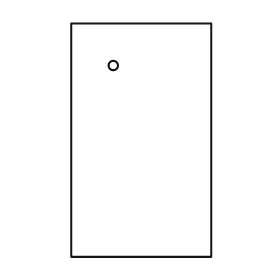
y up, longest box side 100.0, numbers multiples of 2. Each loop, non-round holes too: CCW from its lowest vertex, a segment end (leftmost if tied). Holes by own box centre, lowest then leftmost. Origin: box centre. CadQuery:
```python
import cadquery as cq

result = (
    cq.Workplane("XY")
    .moveTo(-30.0, -50.0)
    .lineTo(30.0, -50.0)
    .lineTo(30.0, 50.0)
    .lineTo(-30.0, 50.0)
    .close()
    .moveTo(-12.0, 32.0)
    .circle(2.0)
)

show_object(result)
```